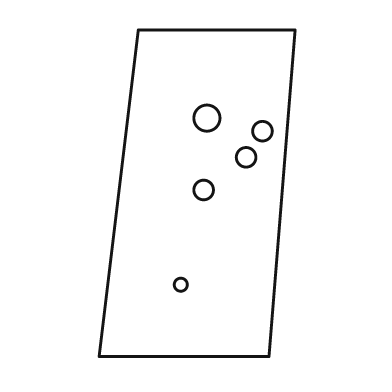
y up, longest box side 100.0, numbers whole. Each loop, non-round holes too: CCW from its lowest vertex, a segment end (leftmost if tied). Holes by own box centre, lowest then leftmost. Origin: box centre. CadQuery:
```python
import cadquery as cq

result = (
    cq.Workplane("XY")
    .moveTo(-30.0, -50.0)
    .lineTo(22.0, -50.0)
    .lineTo(30.0, 50.0)
    .lineTo(-18.0, 50.0)
    .close()
    .moveTo(-5.0, -28.0)
    .circle(2.0)
    .moveTo(2.0, 1.0)
    .circle(3.0)
    .moveTo(15.0, 11.0)
    .circle(3.0)
    .moveTo(20.0, 19.0)
    .circle(3.0)
    .moveTo(3.0, 23.0)
    .circle(4.0)
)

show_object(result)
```